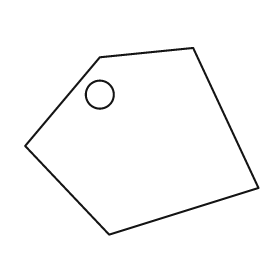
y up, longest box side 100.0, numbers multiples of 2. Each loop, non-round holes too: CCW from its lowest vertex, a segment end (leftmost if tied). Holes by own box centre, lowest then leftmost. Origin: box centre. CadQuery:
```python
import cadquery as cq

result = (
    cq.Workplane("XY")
    .moveTo(-14.0, -40.0)
    .lineTo(50.0, -20.0)
    .lineTo(22.0, 40.0)
    .lineTo(-18.0, 36.0)
    .lineTo(-50.0, -2.0)
    .close()
    .moveTo(-18.0, 20.0)
    .circle(6.0)
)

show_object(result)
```